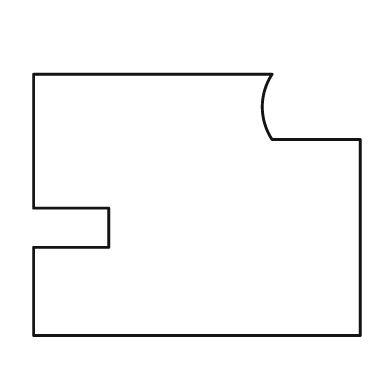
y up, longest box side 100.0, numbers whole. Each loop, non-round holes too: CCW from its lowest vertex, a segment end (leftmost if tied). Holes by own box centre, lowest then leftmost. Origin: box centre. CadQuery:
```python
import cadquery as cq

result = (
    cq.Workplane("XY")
    .moveTo(-50.0, -40.0)
    .lineTo(50.0, -40.0)
    .lineTo(50.0, 20.0)
    .lineTo(23.0, 20.0)
    .threePointArc((20.0, 30.0), (23.0, 40.0))
    .lineTo(-50.0, 40.0)
    .lineTo(-50.0, -1.0)
    .lineTo(-27.0, -1.0)
    .lineTo(-27.0, -13.0)
    .lineTo(-50.0, -13.0)
    .close()
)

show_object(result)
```